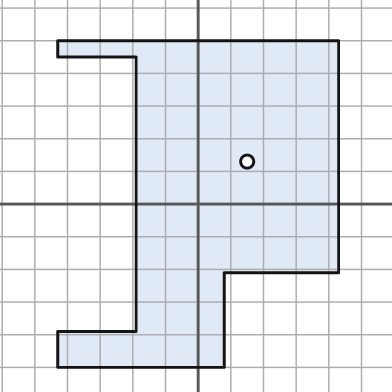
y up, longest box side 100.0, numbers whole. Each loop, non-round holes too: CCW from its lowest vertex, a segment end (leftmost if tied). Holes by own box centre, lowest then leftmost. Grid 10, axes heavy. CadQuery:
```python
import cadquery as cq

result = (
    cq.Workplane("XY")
    .moveTo(-43.0, -50.0)
    .lineTo(8.0, -50.0)
    .lineTo(8.0, -21.0)
    .lineTo(43.0, -21.0)
    .lineTo(43.0, 50.0)
    .lineTo(-43.0, 50.0)
    .lineTo(-43.0, 45.0)
    .lineTo(-19.0, 45.0)
    .lineTo(-19.0, -39.0)
    .lineTo(-43.0, -39.0)
    .close()
    .moveTo(15.0, 13.0)
    .circle(2.0)
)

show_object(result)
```